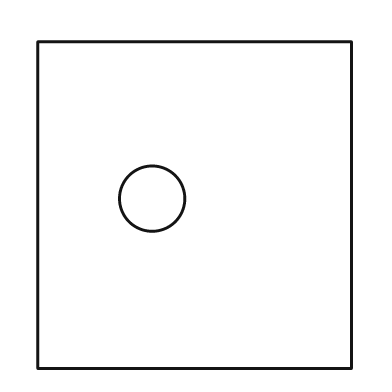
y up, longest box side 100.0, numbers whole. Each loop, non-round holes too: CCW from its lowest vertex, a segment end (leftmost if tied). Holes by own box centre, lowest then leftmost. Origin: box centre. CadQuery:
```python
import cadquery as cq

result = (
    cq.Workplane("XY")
    .moveTo(-48.0, -50.0)
    .lineTo(48.0, -50.0)
    .lineTo(48.0, 50.0)
    .lineTo(-48.0, 50.0)
    .close()
    .moveTo(-13.0, 2.0)
    .circle(10.0)
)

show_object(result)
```